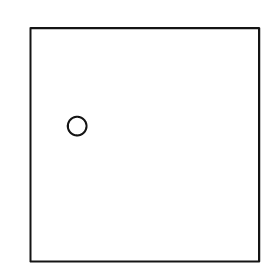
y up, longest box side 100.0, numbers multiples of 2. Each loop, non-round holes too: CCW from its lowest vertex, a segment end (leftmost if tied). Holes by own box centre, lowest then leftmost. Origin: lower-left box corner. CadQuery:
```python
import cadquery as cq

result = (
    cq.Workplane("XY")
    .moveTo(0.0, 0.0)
    .lineTo(98.0, 0.0)
    .lineTo(98.0, 100.0)
    .lineTo(0.0, 100.0)
    .close()
    .moveTo(20.0, 58.0)
    .circle(4.0)
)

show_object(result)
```